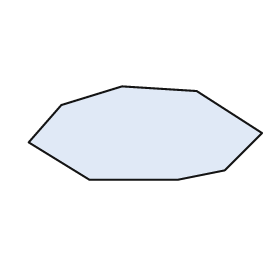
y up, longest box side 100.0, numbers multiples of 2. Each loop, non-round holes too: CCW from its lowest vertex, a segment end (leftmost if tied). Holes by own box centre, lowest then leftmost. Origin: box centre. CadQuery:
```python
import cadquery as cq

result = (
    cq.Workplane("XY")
    .moveTo(-24.0, -20.0)
    .lineTo(14.0, -20.0)
    .lineTo(34.0, -16.0)
    .lineTo(50.0, 0.0)
    .lineTo(22.0, 18.0)
    .lineTo(-10.0, 20.0)
    .lineTo(-36.0, 12.0)
    .lineTo(-50.0, -4.0)
    .close()
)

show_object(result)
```